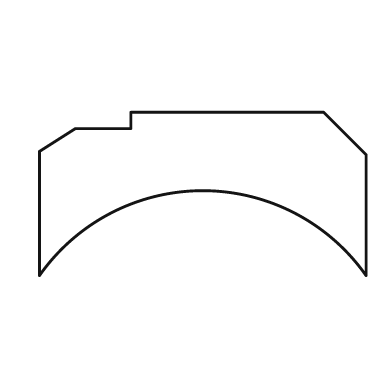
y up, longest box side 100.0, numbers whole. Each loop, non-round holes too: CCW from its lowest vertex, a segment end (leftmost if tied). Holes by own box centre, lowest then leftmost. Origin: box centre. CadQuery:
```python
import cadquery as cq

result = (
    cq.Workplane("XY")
    .moveTo(-50.0, -25.0)
    .threePointArc((0.0, 1.0), (50.0, -25.0))
    .lineTo(50.0, 12.0)
    .lineTo(37.0, 25.0)
    .lineTo(-22.0, 25.0)
    .lineTo(-22.0, 20.0)
    .lineTo(-39.0, 20.0)
    .lineTo(-50.0, 13.0)
    .close()
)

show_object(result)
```